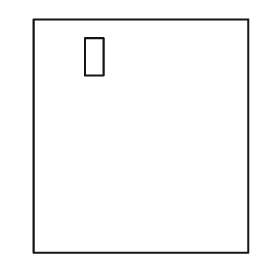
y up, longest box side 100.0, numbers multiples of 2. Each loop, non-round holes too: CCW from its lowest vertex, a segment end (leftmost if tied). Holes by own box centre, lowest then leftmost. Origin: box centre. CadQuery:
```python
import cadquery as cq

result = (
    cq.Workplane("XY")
    .moveTo(-46.0, -50.0)
    .lineTo(46.0, -50.0)
    .lineTo(46.0, 50.0)
    .lineTo(-46.0, 50.0)
    .close()
    .moveTo(-24.0, 26.0)
    .lineTo(-16.0, 26.0)
    .lineTo(-16.0, 42.0)
    .lineTo(-24.0, 42.0)
    .close()
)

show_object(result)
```